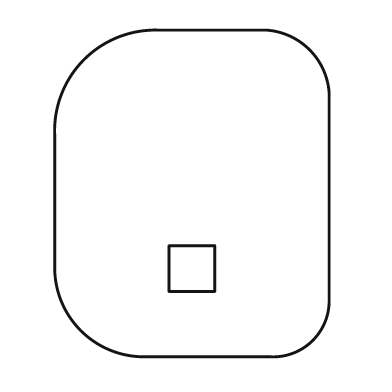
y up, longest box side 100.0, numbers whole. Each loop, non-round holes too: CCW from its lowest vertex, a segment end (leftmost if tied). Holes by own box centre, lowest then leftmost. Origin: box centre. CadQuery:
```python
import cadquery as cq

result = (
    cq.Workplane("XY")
    .moveTo(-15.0, -50.0)
    .lineTo(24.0, -50.0)
    .threePointArc((37.0, -45.0), (42.0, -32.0))
    .lineTo(42.0, 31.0)
    .threePointArc((36.0, 44.0), (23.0, 50.0))
    .lineTo(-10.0, 50.0)
    .threePointArc((-33.0, 41.0), (-42.0, 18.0))
    .lineTo(-42.0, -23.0)
    .threePointArc((-34.0, -42.0), (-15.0, -50.0))
    .close()
    .moveTo(-7.0, -30.0)
    .lineTo(7.0, -30.0)
    .lineTo(7.0, -16.0)
    .lineTo(-7.0, -16.0)
    .close()
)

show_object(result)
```